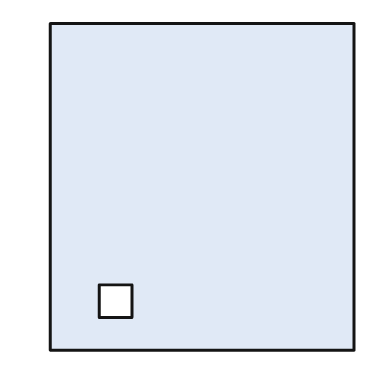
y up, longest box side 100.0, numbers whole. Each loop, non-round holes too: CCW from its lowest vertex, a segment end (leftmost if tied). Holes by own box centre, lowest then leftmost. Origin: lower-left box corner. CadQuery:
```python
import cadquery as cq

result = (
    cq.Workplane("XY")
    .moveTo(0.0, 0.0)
    .lineTo(93.0, 0.0)
    .lineTo(93.0, 100.0)
    .lineTo(0.0, 100.0)
    .close()
    .moveTo(15.0, 10.0)
    .lineTo(25.0, 10.0)
    .lineTo(25.0, 20.0)
    .lineTo(15.0, 20.0)
    .close()
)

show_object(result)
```